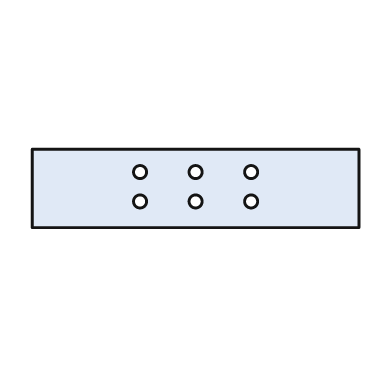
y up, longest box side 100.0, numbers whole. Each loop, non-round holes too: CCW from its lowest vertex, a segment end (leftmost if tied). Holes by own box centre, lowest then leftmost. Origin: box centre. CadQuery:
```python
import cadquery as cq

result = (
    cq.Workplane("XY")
    .moveTo(-50.0, -12.0)
    .lineTo(50.0, -12.0)
    .lineTo(50.0, 12.0)
    .lineTo(-50.0, 12.0)
    .close()
    .moveTo(-17.0, -4.0)
    .circle(2.0)
    .moveTo(0.0, -4.0)
    .circle(2.0)
    .moveTo(17.0, -4.0)
    .circle(2.0)
    .moveTo(-17.0, 5.0)
    .circle(2.0)
    .moveTo(0.0, 5.0)
    .circle(2.0)
    .moveTo(17.0, 5.0)
    .circle(2.0)
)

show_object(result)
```